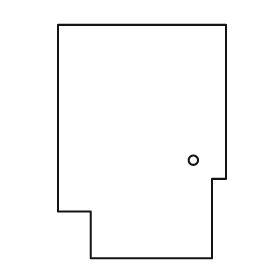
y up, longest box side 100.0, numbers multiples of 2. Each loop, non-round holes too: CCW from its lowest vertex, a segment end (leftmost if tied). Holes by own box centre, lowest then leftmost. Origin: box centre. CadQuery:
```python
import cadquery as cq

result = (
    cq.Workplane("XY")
    .moveTo(-22.0, -50.0)
    .lineTo(30.0, -50.0)
    .lineTo(30.0, -16.0)
    .lineTo(36.0, -16.0)
    .lineTo(36.0, 50.0)
    .lineTo(-36.0, 50.0)
    .lineTo(-36.0, -30.0)
    .lineTo(-22.0, -30.0)
    .close()
    .moveTo(22.0, -8.0)
    .circle(2.0)
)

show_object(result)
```